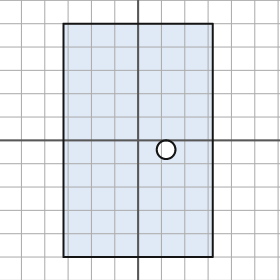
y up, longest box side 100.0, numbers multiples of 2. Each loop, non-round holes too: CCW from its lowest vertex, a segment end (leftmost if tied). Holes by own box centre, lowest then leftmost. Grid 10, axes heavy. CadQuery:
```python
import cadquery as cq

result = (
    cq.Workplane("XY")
    .moveTo(-32.0, -50.0)
    .lineTo(32.0, -50.0)
    .lineTo(32.0, 50.0)
    .lineTo(-32.0, 50.0)
    .close()
    .moveTo(12.0, -4.0)
    .circle(4.0)
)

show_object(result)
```